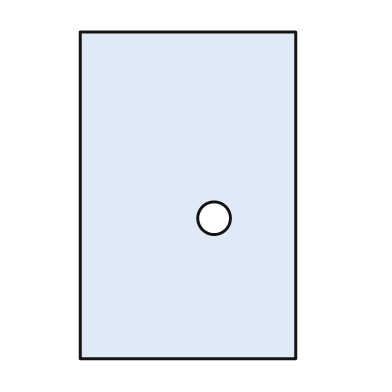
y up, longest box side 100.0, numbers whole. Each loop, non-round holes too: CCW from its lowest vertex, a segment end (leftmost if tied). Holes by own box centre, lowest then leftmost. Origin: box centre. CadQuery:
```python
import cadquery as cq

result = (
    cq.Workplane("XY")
    .moveTo(-33.0, -50.0)
    .lineTo(33.0, -50.0)
    .lineTo(33.0, 50.0)
    .lineTo(-33.0, 50.0)
    .close()
    .moveTo(8.0, -7.0)
    .circle(5.0)
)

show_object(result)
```